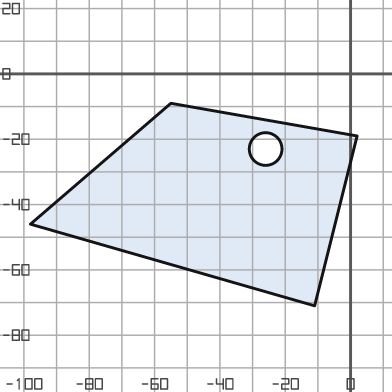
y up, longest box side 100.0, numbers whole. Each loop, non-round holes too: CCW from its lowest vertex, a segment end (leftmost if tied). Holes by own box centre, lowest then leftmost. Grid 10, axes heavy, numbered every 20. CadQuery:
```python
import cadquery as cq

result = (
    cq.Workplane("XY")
    .moveTo(-11.0, -71.0)
    .lineTo(2.0, -19.0)
    .lineTo(-55.0, -9.0)
    .lineTo(-98.0, -46.0)
    .close()
    .moveTo(-26.0, -23.0)
    .circle(5.0)
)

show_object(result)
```